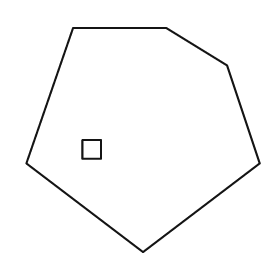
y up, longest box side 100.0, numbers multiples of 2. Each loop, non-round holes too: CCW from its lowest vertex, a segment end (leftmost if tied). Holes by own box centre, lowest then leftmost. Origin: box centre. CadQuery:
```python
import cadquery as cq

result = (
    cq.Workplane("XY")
    .moveTo(0.0, -48.0)
    .lineTo(50.0, -10.0)
    .lineTo(36.0, 32.0)
    .lineTo(10.0, 48.0)
    .lineTo(-30.0, 48.0)
    .lineTo(-50.0, -10.0)
    .close()
    .moveTo(-26.0, -8.0)
    .lineTo(-18.0, -8.0)
    .lineTo(-18.0, 0.0)
    .lineTo(-26.0, 0.0)
    .close()
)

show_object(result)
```